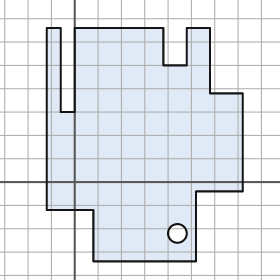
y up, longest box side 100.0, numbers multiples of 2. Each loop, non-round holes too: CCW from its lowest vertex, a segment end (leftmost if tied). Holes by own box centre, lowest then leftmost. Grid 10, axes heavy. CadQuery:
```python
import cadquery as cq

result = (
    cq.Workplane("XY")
    .moveTo(8.0, -34.0)
    .lineTo(52.0, -34.0)
    .lineTo(52.0, -4.0)
    .lineTo(72.0, -4.0)
    .lineTo(72.0, 38.0)
    .lineTo(58.0, 38.0)
    .lineTo(58.0, 66.0)
    .lineTo(48.0, 66.0)
    .lineTo(48.0, 50.0)
    .lineTo(38.0, 50.0)
    .lineTo(38.0, 66.0)
    .lineTo(0.0, 66.0)
    .lineTo(0.0, 30.0)
    .lineTo(-6.0, 30.0)
    .lineTo(-6.0, 66.0)
    .lineTo(-12.0, 66.0)
    .lineTo(-12.0, -12.0)
    .lineTo(8.0, -12.0)
    .close()
    .moveTo(44.0, -22.0)
    .circle(4.0)
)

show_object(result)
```